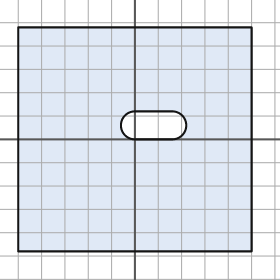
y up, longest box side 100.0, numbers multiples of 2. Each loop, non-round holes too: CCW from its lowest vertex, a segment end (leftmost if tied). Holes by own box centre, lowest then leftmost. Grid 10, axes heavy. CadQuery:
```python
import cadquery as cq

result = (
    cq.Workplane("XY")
    .moveTo(-50.0, -48.0)
    .lineTo(50.0, -48.0)
    .lineTo(50.0, 48.0)
    .lineTo(-50.0, 48.0)
    .close()
    .moveTo(0.0, 0.0)
    .lineTo(16.0, 0.0)
    .threePointArc((22.0, 6.0), (16.0, 12.0))
    .lineTo(0.0, 12.0)
    .threePointArc((-6.0, 6.0), (0.0, 0.0))
    .close()
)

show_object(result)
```